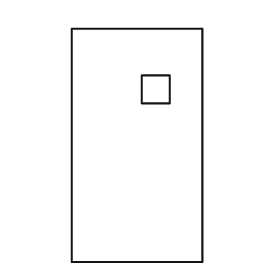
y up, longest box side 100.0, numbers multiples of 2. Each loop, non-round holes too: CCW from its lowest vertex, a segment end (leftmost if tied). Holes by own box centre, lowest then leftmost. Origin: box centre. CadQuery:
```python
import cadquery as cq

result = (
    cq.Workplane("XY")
    .moveTo(-28.0, -50.0)
    .lineTo(28.0, -50.0)
    .lineTo(28.0, 50.0)
    .lineTo(-28.0, 50.0)
    .close()
    .moveTo(2.0, 18.0)
    .lineTo(14.0, 18.0)
    .lineTo(14.0, 30.0)
    .lineTo(2.0, 30.0)
    .close()
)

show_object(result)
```